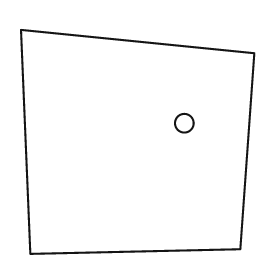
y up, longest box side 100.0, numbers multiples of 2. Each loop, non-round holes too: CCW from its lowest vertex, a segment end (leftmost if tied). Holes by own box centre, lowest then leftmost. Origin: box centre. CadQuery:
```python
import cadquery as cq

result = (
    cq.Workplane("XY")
    .moveTo(-46.0, -48.0)
    .lineTo(44.0, -46.0)
    .lineTo(50.0, 38.0)
    .lineTo(-50.0, 48.0)
    .close()
    .moveTo(20.0, 8.0)
    .circle(4.0)
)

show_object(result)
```